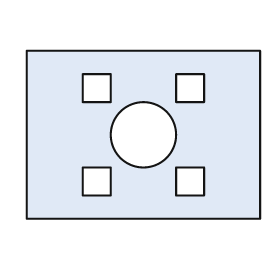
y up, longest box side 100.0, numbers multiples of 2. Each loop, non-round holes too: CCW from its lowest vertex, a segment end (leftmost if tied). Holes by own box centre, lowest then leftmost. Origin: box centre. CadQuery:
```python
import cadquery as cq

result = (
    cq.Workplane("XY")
    .moveTo(-50.0, -36.0)
    .lineTo(50.0, -36.0)
    .lineTo(50.0, 36.0)
    .lineTo(-50.0, 36.0)
    .close()
    .moveTo(-26.0, -26.0)
    .lineTo(-14.0, -26.0)
    .lineTo(-14.0, -14.0)
    .lineTo(-26.0, -14.0)
    .close()
    .moveTo(14.0, -26.0)
    .lineTo(26.0, -26.0)
    .lineTo(26.0, -14.0)
    .lineTo(14.0, -14.0)
    .close()
    .moveTo(0.0, 0.0)
    .circle(14.0)
    .moveTo(-26.0, 14.0)
    .lineTo(-14.0, 14.0)
    .lineTo(-14.0, 26.0)
    .lineTo(-26.0, 26.0)
    .close()
    .moveTo(14.0, 14.0)
    .lineTo(26.0, 14.0)
    .lineTo(26.0, 26.0)
    .lineTo(14.0, 26.0)
    .close()
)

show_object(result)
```